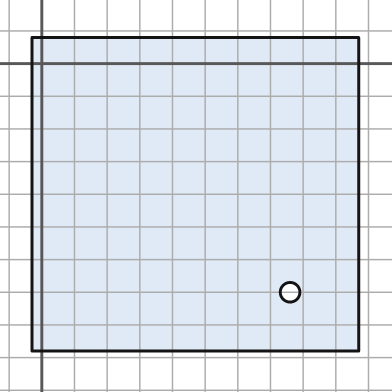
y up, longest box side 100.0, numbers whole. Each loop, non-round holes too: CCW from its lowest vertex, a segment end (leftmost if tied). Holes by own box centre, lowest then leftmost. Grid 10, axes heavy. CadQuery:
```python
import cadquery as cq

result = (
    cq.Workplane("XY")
    .moveTo(-3.0, -88.0)
    .lineTo(97.0, -88.0)
    .lineTo(97.0, 8.0)
    .lineTo(-3.0, 8.0)
    .close()
    .moveTo(76.0, -70.0)
    .circle(3.0)
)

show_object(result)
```